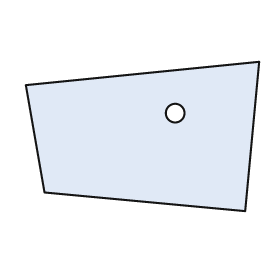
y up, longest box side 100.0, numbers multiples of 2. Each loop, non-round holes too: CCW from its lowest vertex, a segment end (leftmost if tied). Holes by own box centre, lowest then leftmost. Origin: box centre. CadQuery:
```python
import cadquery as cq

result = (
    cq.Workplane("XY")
    .moveTo(44.0, -32.0)
    .lineTo(50.0, 32.0)
    .lineTo(-50.0, 22.0)
    .lineTo(-42.0, -24.0)
    .close()
    .moveTo(14.0, 10.0)
    .circle(4.0)
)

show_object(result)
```